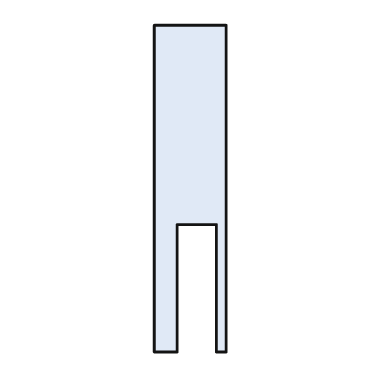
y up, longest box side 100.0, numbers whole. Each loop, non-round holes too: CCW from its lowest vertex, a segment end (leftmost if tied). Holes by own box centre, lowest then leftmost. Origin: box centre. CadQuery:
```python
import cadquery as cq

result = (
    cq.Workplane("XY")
    .moveTo(-11.0, -50.0)
    .lineTo(-4.0, -50.0)
    .lineTo(-4.0, -11.0)
    .lineTo(8.0, -11.0)
    .lineTo(8.0, -50.0)
    .lineTo(11.0, -50.0)
    .lineTo(11.0, 50.0)
    .lineTo(-11.0, 50.0)
    .close()
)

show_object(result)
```